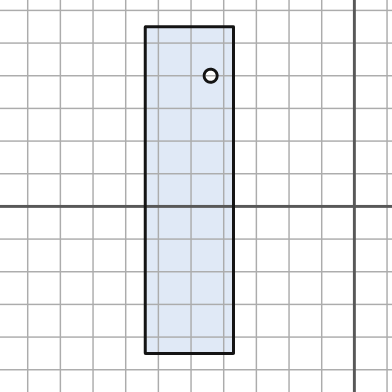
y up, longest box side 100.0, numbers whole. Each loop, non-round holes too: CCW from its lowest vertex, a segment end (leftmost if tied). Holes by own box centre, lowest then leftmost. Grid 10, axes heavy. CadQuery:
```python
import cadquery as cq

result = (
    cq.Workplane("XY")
    .moveTo(-64.0, -45.0)
    .lineTo(-37.0, -45.0)
    .lineTo(-37.0, 55.0)
    .lineTo(-64.0, 55.0)
    .close()
    .moveTo(-44.0, 40.0)
    .circle(2.0)
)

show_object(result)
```